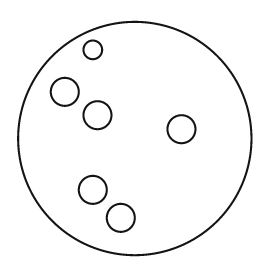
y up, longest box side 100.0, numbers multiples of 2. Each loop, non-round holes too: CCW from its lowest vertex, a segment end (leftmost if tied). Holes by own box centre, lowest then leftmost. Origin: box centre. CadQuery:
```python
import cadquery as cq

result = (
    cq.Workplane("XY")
    .moveTo(0.0, 0.0)
    .circle(50.0)
    .moveTo(-6.0, -34.0)
    .circle(6.0)
    .moveTo(-18.0, -22.0)
    .circle(6.0)
    .moveTo(20.0, 4.0)
    .circle(6.0)
    .moveTo(-16.0, 10.0)
    .circle(6.0)
    .moveTo(-30.0, 20.0)
    .circle(6.0)
    .moveTo(-18.0, 38.0)
    .circle(4.0)
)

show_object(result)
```